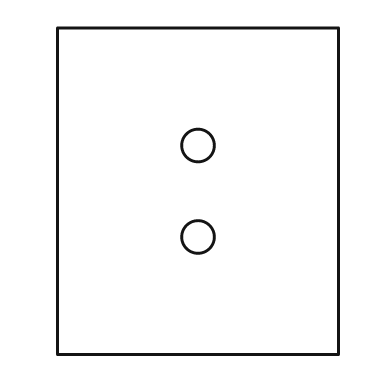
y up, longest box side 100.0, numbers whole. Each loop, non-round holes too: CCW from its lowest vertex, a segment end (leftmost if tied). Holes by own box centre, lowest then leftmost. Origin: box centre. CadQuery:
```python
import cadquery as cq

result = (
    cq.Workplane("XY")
    .moveTo(-43.0, -50.0)
    .lineTo(43.0, -50.0)
    .lineTo(43.0, 50.0)
    .lineTo(-43.0, 50.0)
    .close()
    .moveTo(0.0, -14.0)
    .circle(5.0)
    .moveTo(0.0, 14.0)
    .circle(5.0)
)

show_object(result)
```